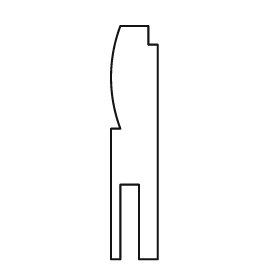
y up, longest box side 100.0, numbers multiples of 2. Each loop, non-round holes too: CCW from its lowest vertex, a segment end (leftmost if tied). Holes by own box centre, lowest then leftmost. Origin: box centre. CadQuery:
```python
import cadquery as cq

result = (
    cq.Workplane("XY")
    .moveTo(-10.0, -50.0)
    .lineTo(-6.0, -50.0)
    .lineTo(-6.0, -18.0)
    .lineTo(2.0, -18.0)
    .lineTo(2.0, -50.0)
    .lineTo(10.0, -50.0)
    .lineTo(10.0, 42.0)
    .lineTo(6.0, 42.0)
    .lineTo(6.0, 50.0)
    .lineTo(-6.0, 50.0)
    .threePointArc((-10.0, 28.0), (-6.0, 6.0))
    .lineTo(-10.0, 6.0)
    .close()
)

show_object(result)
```